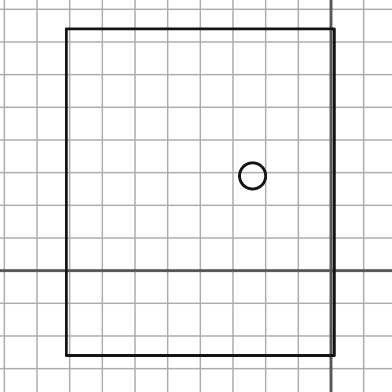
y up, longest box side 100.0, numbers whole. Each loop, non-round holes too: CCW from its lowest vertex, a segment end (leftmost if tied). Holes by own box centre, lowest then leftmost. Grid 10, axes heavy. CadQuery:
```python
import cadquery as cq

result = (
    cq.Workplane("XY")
    .moveTo(-81.0, -26.0)
    .lineTo(1.0, -26.0)
    .lineTo(1.0, 74.0)
    .lineTo(-81.0, 74.0)
    .close()
    .moveTo(-24.0, 29.0)
    .circle(4.0)
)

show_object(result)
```